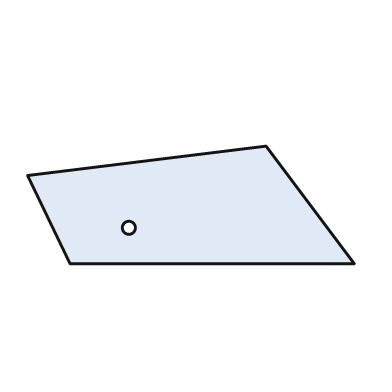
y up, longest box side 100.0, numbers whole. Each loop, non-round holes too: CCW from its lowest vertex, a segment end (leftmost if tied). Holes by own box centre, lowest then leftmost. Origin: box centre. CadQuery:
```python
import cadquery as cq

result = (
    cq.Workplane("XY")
    .moveTo(-37.0, -18.0)
    .lineTo(50.0, -18.0)
    .lineTo(23.0, 18.0)
    .lineTo(-50.0, 9.0)
    .close()
    .moveTo(-19.0, -7.0)
    .circle(2.0)
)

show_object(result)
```